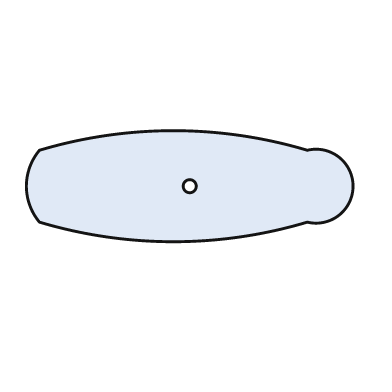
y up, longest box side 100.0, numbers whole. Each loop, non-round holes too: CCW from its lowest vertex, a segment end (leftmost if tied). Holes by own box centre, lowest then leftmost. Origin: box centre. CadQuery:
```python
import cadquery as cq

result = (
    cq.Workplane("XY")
    .moveTo(-46.0, -11.0)
    .threePointArc((-5.0, -17.0), (36.0, -11.0))
    .threePointArc((50.0, 0.0), (36.0, 11.0))
    .threePointArc((-5.0, 17.0), (-46.0, 11.0))
    .threePointArc((-50.0, 0.0), (-46.0, -11.0))
    .close()
    .moveTo(0.0, 0.0)
    .circle(2.0)
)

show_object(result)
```